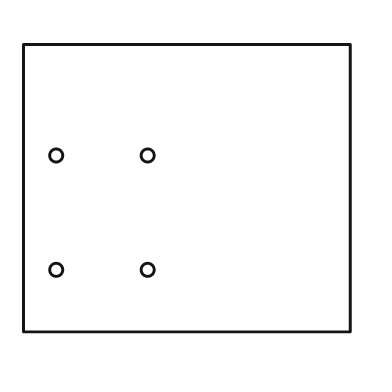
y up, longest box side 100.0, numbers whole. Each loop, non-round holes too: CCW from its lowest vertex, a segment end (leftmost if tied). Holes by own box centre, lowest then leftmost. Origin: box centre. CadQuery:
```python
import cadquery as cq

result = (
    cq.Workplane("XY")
    .moveTo(-50.0, -44.0)
    .lineTo(50.0, -44.0)
    .lineTo(50.0, 44.0)
    .lineTo(-50.0, 44.0)
    .close()
    .moveTo(-40.0, -25.0)
    .circle(2.0)
    .moveTo(-12.0, -25.0)
    .circle(2.0)
    .moveTo(-40.0, 10.0)
    .circle(2.0)
    .moveTo(-12.0, 10.0)
    .circle(2.0)
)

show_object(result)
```